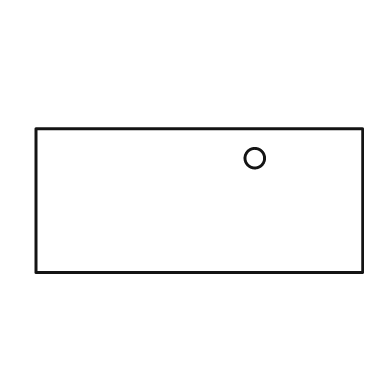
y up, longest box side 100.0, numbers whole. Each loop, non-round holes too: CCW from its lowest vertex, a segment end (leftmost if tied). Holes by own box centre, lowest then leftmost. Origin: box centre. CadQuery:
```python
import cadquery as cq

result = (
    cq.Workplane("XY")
    .moveTo(-50.0, -22.0)
    .lineTo(50.0, -22.0)
    .lineTo(50.0, 22.0)
    .lineTo(-50.0, 22.0)
    .close()
    .moveTo(17.0, 13.0)
    .circle(3.0)
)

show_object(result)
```